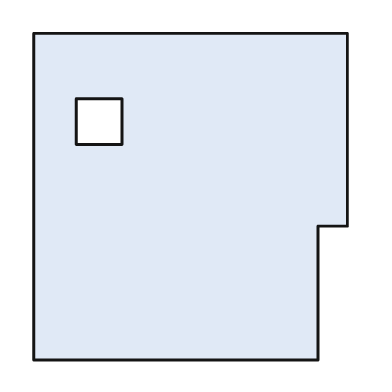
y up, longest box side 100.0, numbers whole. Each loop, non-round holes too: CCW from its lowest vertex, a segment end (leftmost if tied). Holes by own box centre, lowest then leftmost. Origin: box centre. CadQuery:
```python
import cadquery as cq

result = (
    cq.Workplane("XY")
    .moveTo(-48.0, -50.0)
    .lineTo(39.0, -50.0)
    .lineTo(39.0, -9.0)
    .lineTo(48.0, -9.0)
    .lineTo(48.0, 50.0)
    .lineTo(-48.0, 50.0)
    .close()
    .moveTo(-35.0, 16.0)
    .lineTo(-21.0, 16.0)
    .lineTo(-21.0, 30.0)
    .lineTo(-35.0, 30.0)
    .close()
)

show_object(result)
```